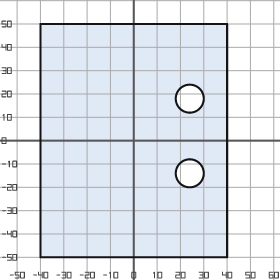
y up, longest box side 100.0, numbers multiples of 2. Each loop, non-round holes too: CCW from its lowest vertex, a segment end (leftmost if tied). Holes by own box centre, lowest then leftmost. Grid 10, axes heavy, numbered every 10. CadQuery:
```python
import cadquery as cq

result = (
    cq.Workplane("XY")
    .moveTo(-40.0, -50.0)
    .lineTo(40.0, -50.0)
    .lineTo(40.0, 50.0)
    .lineTo(-40.0, 50.0)
    .close()
    .moveTo(24.0, -14.0)
    .circle(6.0)
    .moveTo(24.0, 18.0)
    .circle(6.0)
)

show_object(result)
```